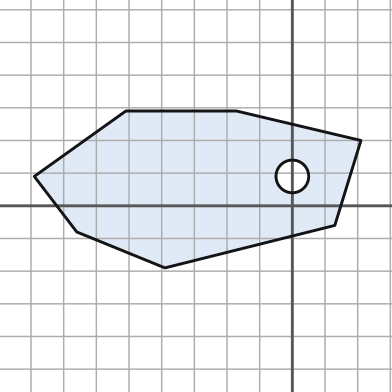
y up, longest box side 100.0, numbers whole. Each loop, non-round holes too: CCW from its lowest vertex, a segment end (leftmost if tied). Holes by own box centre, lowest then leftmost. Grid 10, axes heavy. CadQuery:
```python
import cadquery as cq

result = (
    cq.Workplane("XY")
    .moveTo(-39.0, -19.0)
    .lineTo(13.0, -6.0)
    .lineTo(21.0, 20.0)
    .lineTo(-17.0, 29.0)
    .lineTo(-51.0, 29.0)
    .lineTo(-79.0, 9.0)
    .lineTo(-66.0, -8.0)
    .close()
    .moveTo(0.0, 9.0)
    .circle(5.0)
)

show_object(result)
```